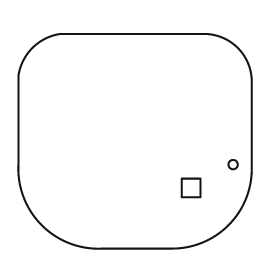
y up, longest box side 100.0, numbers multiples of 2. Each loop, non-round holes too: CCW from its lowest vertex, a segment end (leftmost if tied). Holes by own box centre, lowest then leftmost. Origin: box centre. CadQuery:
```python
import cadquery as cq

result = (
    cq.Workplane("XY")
    .moveTo(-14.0, -46.0)
    .lineTo(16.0, -46.0)
    .threePointArc((40.0, -36.0), (50.0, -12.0))
    .lineTo(50.0, 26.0)
    .threePointArc((44.0, 40.0), (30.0, 46.0))
    .lineTo(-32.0, 46.0)
    .threePointArc((-44.0, 40.0), (-50.0, 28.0))
    .lineTo(-50.0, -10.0)
    .threePointArc((-40.0, -36.0), (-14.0, -46.0))
    .close()
    .moveTo(20.0, -24.0)
    .lineTo(28.0, -24.0)
    .lineTo(28.0, -16.0)
    .lineTo(20.0, -16.0)
    .close()
    .moveTo(42.0, -10.0)
    .circle(2.0)
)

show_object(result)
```